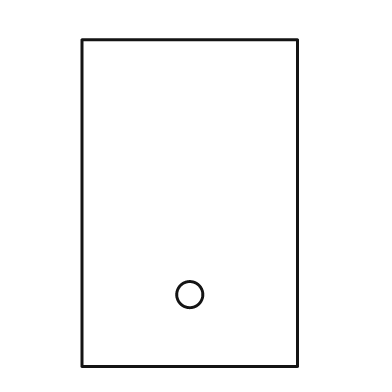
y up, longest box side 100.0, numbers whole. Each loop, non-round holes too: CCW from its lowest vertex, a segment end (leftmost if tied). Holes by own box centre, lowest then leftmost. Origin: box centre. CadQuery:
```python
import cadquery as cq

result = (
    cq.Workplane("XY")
    .moveTo(-33.0, -50.0)
    .lineTo(33.0, -50.0)
    .lineTo(33.0, 50.0)
    .lineTo(-33.0, 50.0)
    .close()
    .moveTo(0.0, -28.0)
    .circle(4.0)
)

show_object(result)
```